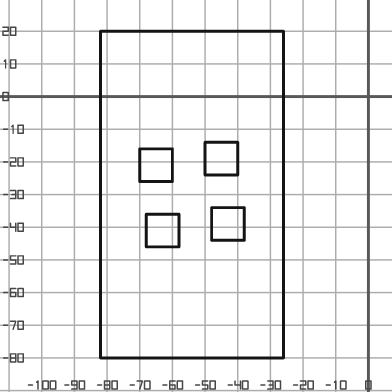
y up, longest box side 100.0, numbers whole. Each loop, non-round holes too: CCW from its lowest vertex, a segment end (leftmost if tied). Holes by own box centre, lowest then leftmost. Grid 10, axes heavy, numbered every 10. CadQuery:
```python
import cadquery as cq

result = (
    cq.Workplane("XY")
    .moveTo(-82.0, -80.0)
    .lineTo(-26.0, -80.0)
    .lineTo(-26.0, 20.0)
    .lineTo(-82.0, 20.0)
    .close()
    .moveTo(-68.0, -46.0)
    .lineTo(-58.0, -46.0)
    .lineTo(-58.0, -36.0)
    .lineTo(-68.0, -36.0)
    .close()
    .moveTo(-48.0, -44.0)
    .lineTo(-38.0, -44.0)
    .lineTo(-38.0, -34.0)
    .lineTo(-48.0, -34.0)
    .close()
    .moveTo(-70.0, -26.0)
    .lineTo(-60.0, -26.0)
    .lineTo(-60.0, -16.0)
    .lineTo(-70.0, -16.0)
    .close()
    .moveTo(-50.0, -24.0)
    .lineTo(-40.0, -24.0)
    .lineTo(-40.0, -14.0)
    .lineTo(-50.0, -14.0)
    .close()
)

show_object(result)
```